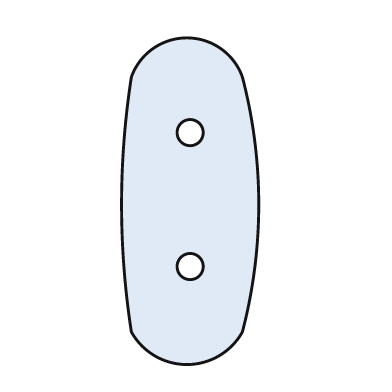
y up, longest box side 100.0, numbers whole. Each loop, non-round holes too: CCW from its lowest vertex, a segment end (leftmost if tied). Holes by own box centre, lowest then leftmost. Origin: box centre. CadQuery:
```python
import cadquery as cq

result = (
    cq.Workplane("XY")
    .moveTo(-18.0, -40.0)
    .threePointArc((-1.0, -50.0), (16.0, -40.0))
    .threePointArc((21.0, -1.0), (16.0, 38.0))
    .threePointArc((-1.0, 50.0), (-18.0, 38.0))
    .threePointArc((-21.0, -1.0), (-18.0, -40.0))
    .close()
    .moveTo(0.0, -20.0)
    .circle(4.0)
    .moveTo(0.0, 21.0)
    .circle(4.0)
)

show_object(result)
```